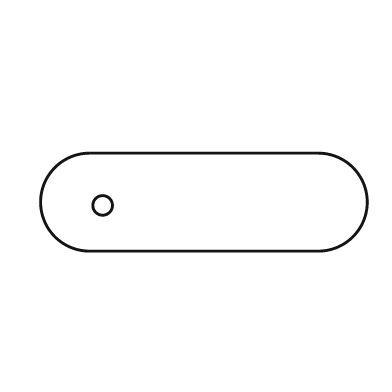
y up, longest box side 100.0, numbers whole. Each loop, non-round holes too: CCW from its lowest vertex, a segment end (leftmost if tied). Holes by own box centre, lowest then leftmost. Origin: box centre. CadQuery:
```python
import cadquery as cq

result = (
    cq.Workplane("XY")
    .moveTo(-35.0, -15.0)
    .lineTo(35.0, -15.0)
    .threePointArc((50.0, 0.0), (35.0, 15.0))
    .lineTo(-35.0, 15.0)
    .threePointArc((-50.0, 0.0), (-35.0, -15.0))
    .close()
    .moveTo(-31.0, -1.0)
    .circle(3.0)
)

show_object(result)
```